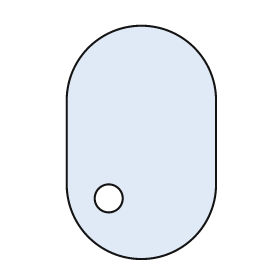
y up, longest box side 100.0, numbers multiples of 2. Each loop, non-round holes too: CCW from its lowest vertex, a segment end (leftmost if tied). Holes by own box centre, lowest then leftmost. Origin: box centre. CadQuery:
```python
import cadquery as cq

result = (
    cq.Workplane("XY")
    .moveTo(-32.0, -18.0)
    .threePointArc((0.0, -50.0), (32.0, -18.0))
    .lineTo(32.0, 18.0)
    .threePointArc((0.0, 50.0), (-32.0, 18.0))
    .close()
    .moveTo(-14.0, -24.0)
    .circle(6.0)
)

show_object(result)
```